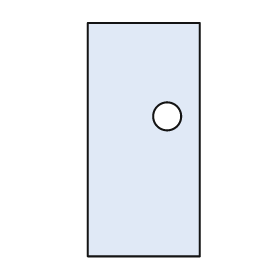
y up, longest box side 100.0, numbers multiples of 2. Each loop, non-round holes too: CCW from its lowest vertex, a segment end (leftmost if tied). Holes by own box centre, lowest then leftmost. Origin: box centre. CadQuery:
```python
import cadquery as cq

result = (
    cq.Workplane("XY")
    .moveTo(-24.0, -50.0)
    .lineTo(24.0, -50.0)
    .lineTo(24.0, 50.0)
    .lineTo(-24.0, 50.0)
    .close()
    .moveTo(10.0, 10.0)
    .circle(6.0)
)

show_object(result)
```